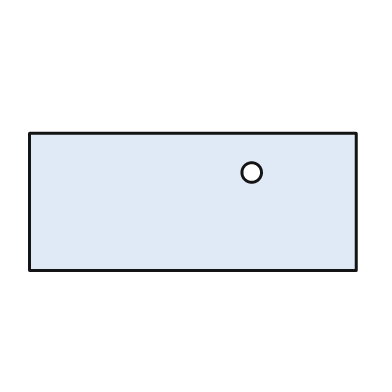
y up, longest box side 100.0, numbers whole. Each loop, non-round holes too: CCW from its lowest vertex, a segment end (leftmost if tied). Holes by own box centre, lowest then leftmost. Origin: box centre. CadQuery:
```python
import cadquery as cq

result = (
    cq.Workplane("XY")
    .moveTo(-50.0, -21.0)
    .lineTo(50.0, -21.0)
    .lineTo(50.0, 21.0)
    .lineTo(-50.0, 21.0)
    .close()
    .moveTo(18.0, 9.0)
    .circle(3.0)
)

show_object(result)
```